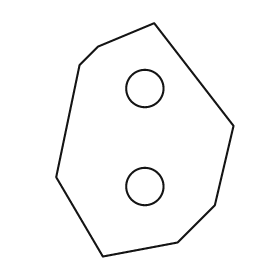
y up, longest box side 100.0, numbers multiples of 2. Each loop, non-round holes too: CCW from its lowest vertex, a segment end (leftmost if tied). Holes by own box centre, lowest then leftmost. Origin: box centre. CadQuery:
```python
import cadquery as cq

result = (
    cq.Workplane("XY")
    .moveTo(-18.0, -50.0)
    .lineTo(14.0, -44.0)
    .lineTo(30.0, -28.0)
    .lineTo(38.0, 6.0)
    .lineTo(4.0, 50.0)
    .lineTo(-20.0, 40.0)
    .lineTo(-28.0, 32.0)
    .lineTo(-38.0, -16.0)
    .close()
    .moveTo(0.0, -20.0)
    .circle(8.0)
    .moveTo(0.0, 22.0)
    .circle(8.0)
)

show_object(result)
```